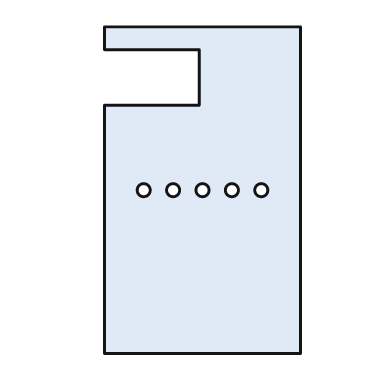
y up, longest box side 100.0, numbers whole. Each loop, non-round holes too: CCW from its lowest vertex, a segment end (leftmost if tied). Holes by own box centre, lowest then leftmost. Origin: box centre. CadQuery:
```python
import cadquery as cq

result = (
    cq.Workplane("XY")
    .moveTo(-30.0, -50.0)
    .lineTo(30.0, -50.0)
    .lineTo(30.0, 50.0)
    .lineTo(-30.0, 50.0)
    .lineTo(-30.0, 43.0)
    .lineTo(-1.0, 43.0)
    .lineTo(-1.0, 26.0)
    .lineTo(-30.0, 26.0)
    .close()
    .moveTo(-18.0, 0.0)
    .circle(2.0)
    .moveTo(-9.0, 0.0)
    .circle(2.0)
    .moveTo(0.0, 0.0)
    .circle(2.0)
    .moveTo(9.0, 0.0)
    .circle(2.0)
    .moveTo(18.0, 0.0)
    .circle(2.0)
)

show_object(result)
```